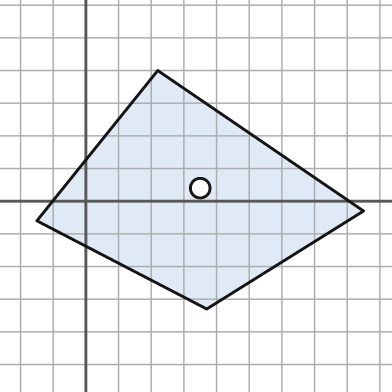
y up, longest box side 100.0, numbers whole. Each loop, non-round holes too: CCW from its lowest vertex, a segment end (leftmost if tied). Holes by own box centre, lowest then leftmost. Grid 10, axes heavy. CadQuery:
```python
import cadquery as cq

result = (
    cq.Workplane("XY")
    .moveTo(37.0, -33.0)
    .lineTo(85.0, -3.0)
    .lineTo(22.0, 40.0)
    .lineTo(-15.0, -6.0)
    .close()
    .moveTo(35.0, 4.0)
    .circle(3.0)
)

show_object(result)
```